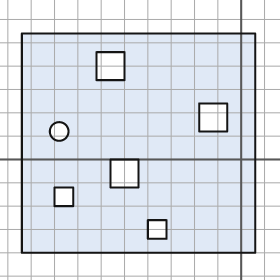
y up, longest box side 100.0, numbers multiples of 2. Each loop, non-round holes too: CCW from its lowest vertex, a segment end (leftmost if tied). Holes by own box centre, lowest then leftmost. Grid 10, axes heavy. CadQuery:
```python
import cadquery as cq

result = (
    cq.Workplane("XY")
    .moveTo(-94.0, -40.0)
    .lineTo(6.0, -40.0)
    .lineTo(6.0, 54.0)
    .lineTo(-94.0, 54.0)
    .close()
    .moveTo(-40.0, -34.0)
    .lineTo(-32.0, -34.0)
    .lineTo(-32.0, -26.0)
    .lineTo(-40.0, -26.0)
    .close()
    .moveTo(-80.0, -20.0)
    .lineTo(-72.0, -20.0)
    .lineTo(-72.0, -12.0)
    .lineTo(-80.0, -12.0)
    .close()
    .moveTo(-56.0, -12.0)
    .lineTo(-44.0, -12.0)
    .lineTo(-44.0, 0.0)
    .lineTo(-56.0, 0.0)
    .close()
    .moveTo(-78.0, 12.0)
    .circle(4.0)
    .moveTo(-18.0, 12.0)
    .lineTo(-6.0, 12.0)
    .lineTo(-6.0, 24.0)
    .lineTo(-18.0, 24.0)
    .close()
    .moveTo(-62.0, 34.0)
    .lineTo(-50.0, 34.0)
    .lineTo(-50.0, 46.0)
    .lineTo(-62.0, 46.0)
    .close()
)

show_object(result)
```